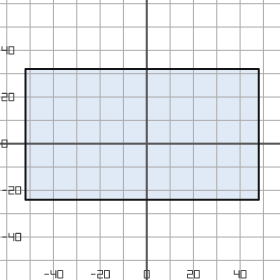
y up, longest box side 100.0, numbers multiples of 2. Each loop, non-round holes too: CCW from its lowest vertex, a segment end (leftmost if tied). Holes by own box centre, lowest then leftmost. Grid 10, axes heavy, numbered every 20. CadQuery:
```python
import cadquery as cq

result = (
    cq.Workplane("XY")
    .moveTo(-52.0, -24.0)
    .lineTo(48.0, -24.0)
    .lineTo(48.0, 32.0)
    .lineTo(-52.0, 32.0)
    .close()
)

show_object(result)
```